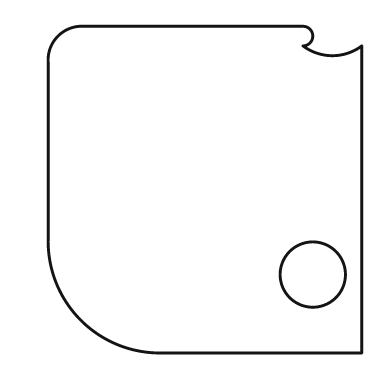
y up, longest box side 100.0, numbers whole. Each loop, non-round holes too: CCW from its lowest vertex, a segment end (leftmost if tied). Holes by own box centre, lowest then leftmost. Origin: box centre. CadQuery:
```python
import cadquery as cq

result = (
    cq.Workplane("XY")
    .moveTo(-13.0, -50.0)
    .lineTo(48.0, -50.0)
    .lineTo(48.0, 44.0)
    .threePointArc((39.0, 41.0), (30.0, 44.0))
    .threePointArc((33.0, 47.0), (30.0, 50.0))
    .lineTo(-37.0, 50.0)
    .threePointArc((-45.0, 47.0), (-48.0, 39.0))
    .lineTo(-48.0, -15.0)
    .threePointArc((-38.0, -40.0), (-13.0, -50.0))
    .close()
    .moveTo(33.0, -26.0)
    .circle(10.0)
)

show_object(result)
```